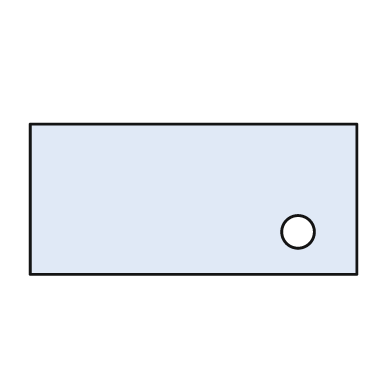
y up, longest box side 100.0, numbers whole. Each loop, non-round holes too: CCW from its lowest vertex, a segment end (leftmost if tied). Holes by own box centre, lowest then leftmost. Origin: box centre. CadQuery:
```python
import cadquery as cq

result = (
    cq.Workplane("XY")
    .moveTo(-50.0, -23.0)
    .lineTo(50.0, -23.0)
    .lineTo(50.0, 23.0)
    .lineTo(-50.0, 23.0)
    .close()
    .moveTo(32.0, -10.0)
    .circle(5.0)
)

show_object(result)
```